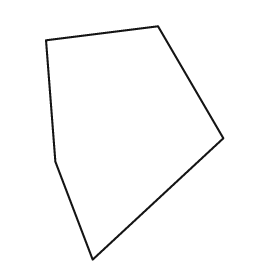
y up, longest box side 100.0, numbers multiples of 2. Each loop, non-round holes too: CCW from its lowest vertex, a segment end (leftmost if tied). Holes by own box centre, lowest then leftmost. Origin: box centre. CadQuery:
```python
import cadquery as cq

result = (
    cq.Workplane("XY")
    .moveTo(-18.0, -50.0)
    .lineTo(38.0, 2.0)
    .lineTo(10.0, 50.0)
    .lineTo(-38.0, 44.0)
    .lineTo(-34.0, -8.0)
    .close()
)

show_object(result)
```